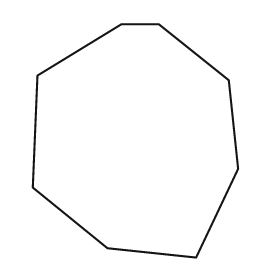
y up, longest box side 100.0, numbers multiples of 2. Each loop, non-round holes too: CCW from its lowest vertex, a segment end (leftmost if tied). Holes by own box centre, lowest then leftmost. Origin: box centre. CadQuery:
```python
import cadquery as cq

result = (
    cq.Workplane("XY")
    .moveTo(26.0, -50.0)
    .lineTo(44.0, -12.0)
    .lineTo(40.0, 26.0)
    .lineTo(10.0, 50.0)
    .lineTo(-6.0, 50.0)
    .lineTo(-42.0, 28.0)
    .lineTo(-44.0, -20.0)
    .lineTo(-12.0, -46.0)
    .close()
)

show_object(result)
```